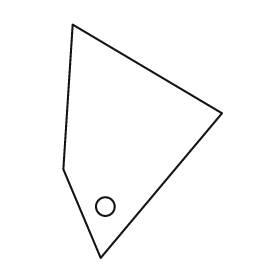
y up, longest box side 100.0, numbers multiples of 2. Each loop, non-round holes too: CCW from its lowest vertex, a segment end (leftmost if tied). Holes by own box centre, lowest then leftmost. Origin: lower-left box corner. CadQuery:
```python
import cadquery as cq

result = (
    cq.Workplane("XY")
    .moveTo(16.0, 0.0)
    .lineTo(68.0, 62.0)
    .lineTo(4.0, 100.0)
    .lineTo(0.0, 38.0)
    .close()
    .moveTo(18.0, 22.0)
    .circle(4.0)
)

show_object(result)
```